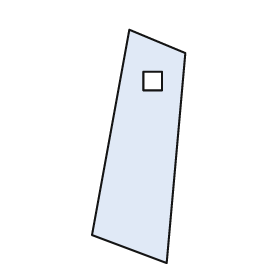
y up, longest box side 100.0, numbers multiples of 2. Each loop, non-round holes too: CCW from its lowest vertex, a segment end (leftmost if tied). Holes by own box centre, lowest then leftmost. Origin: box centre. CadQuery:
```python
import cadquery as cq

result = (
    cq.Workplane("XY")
    .moveTo(12.0, -50.0)
    .lineTo(20.0, 40.0)
    .lineTo(-4.0, 50.0)
    .lineTo(-20.0, -38.0)
    .close()
    .moveTo(2.0, 24.0)
    .lineTo(10.0, 24.0)
    .lineTo(10.0, 32.0)
    .lineTo(2.0, 32.0)
    .close()
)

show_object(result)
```